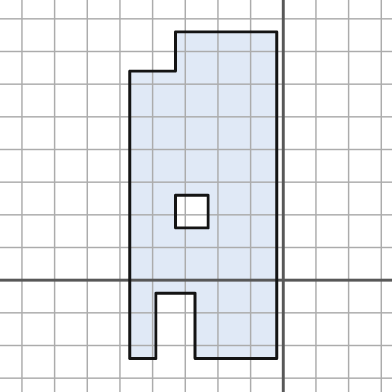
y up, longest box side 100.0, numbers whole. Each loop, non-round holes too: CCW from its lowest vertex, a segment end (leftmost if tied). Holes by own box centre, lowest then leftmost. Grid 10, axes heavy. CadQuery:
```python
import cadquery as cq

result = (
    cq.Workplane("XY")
    .moveTo(-47.0, -24.0)
    .lineTo(-39.0, -24.0)
    .lineTo(-39.0, -4.0)
    .lineTo(-27.0, -4.0)
    .lineTo(-27.0, -24.0)
    .lineTo(-2.0, -24.0)
    .lineTo(-2.0, 76.0)
    .lineTo(-33.0, 76.0)
    .lineTo(-33.0, 64.0)
    .lineTo(-47.0, 64.0)
    .close()
    .moveTo(-33.0, 16.0)
    .lineTo(-23.0, 16.0)
    .lineTo(-23.0, 26.0)
    .lineTo(-33.0, 26.0)
    .close()
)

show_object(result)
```